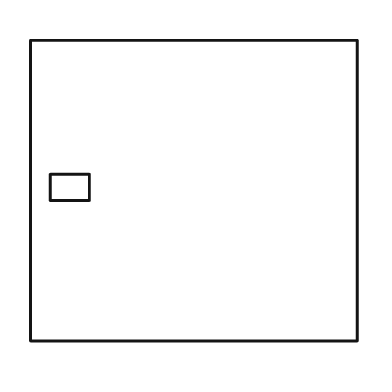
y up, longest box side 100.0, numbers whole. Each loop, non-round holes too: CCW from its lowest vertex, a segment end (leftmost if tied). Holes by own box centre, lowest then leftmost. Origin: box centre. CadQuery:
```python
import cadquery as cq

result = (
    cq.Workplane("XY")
    .moveTo(-50.0, -46.0)
    .lineTo(50.0, -46.0)
    .lineTo(50.0, 46.0)
    .lineTo(-50.0, 46.0)
    .close()
    .moveTo(-44.0, -3.0)
    .lineTo(-32.0, -3.0)
    .lineTo(-32.0, 5.0)
    .lineTo(-44.0, 5.0)
    .close()
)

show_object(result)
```